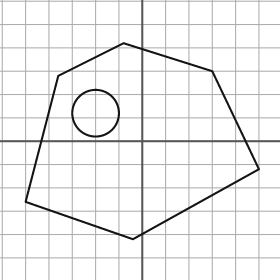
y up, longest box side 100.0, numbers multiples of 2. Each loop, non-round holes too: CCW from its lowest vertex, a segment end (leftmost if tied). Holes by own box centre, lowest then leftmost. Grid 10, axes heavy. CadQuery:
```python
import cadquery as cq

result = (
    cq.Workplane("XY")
    .moveTo(-4.0, -42.0)
    .lineTo(50.0, -12.0)
    .lineTo(30.0, 30.0)
    .lineTo(-8.0, 42.0)
    .lineTo(-36.0, 28.0)
    .lineTo(-50.0, -26.0)
    .close()
    .moveTo(-20.0, 12.0)
    .circle(10.0)
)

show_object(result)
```